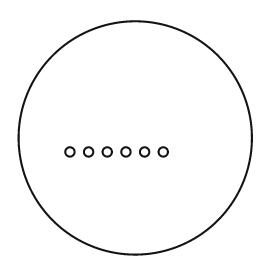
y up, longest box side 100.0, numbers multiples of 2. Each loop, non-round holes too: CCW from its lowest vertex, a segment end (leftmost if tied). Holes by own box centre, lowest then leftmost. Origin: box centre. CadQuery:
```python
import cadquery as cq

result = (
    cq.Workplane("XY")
    .moveTo(0.0, 0.0)
    .circle(50.0)
    .moveTo(-28.0, -6.0)
    .circle(2.0)
    .moveTo(-20.0, -6.0)
    .circle(2.0)
    .moveTo(-12.0, -6.0)
    .circle(2.0)
    .moveTo(-4.0, -6.0)
    .circle(2.0)
    .moveTo(4.0, -6.0)
    .circle(2.0)
    .moveTo(12.0, -6.0)
    .circle(2.0)
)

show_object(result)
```